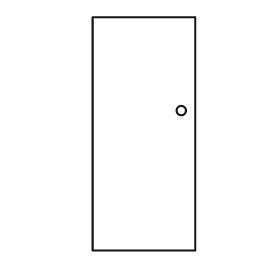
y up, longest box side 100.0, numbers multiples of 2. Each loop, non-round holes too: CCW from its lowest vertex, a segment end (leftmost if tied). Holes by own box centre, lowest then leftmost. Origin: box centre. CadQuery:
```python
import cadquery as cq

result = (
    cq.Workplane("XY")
    .moveTo(-22.0, -50.0)
    .lineTo(22.0, -50.0)
    .lineTo(22.0, 50.0)
    .lineTo(-22.0, 50.0)
    .close()
    .moveTo(16.0, 10.0)
    .circle(2.0)
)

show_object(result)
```